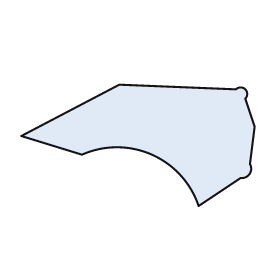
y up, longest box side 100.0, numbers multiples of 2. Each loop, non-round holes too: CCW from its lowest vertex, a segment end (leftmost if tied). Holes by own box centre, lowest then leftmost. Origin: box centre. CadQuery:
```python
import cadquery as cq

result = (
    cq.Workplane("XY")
    .moveTo(26.0, -26.0)
    .lineTo(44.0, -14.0)
    .threePointArc((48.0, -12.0), (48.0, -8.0))
    .lineTo(50.0, 8.0)
    .lineTo(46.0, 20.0)
    .threePointArc((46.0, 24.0), (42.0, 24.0))
    .lineTo(-8.0, 26.0)
    .lineTo(-50.0, 4.0)
    .lineTo(-24.0, -4.0)
    .threePointArc((6.0, -4.0), (26.0, -26.0))
    .close()
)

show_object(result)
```